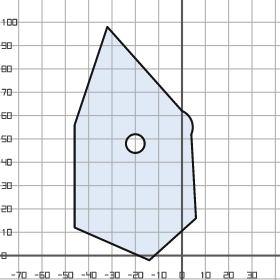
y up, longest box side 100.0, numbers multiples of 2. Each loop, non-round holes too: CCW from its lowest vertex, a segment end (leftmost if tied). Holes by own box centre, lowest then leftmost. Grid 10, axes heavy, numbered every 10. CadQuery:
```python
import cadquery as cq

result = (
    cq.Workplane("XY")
    .moveTo(-14.0, -2.0)
    .lineTo(6.0, 16.0)
    .lineTo(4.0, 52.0)
    .threePointArc((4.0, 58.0), (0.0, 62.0))
    .lineTo(-32.0, 98.0)
    .lineTo(-46.0, 56.0)
    .lineTo(-46.0, 12.0)
    .close()
    .moveTo(-20.0, 48.0)
    .circle(4.0)
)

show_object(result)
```